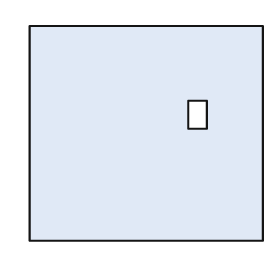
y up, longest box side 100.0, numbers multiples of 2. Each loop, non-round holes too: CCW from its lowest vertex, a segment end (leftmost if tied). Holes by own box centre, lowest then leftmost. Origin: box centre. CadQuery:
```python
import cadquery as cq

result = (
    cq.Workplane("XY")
    .moveTo(-50.0, -46.0)
    .lineTo(50.0, -46.0)
    .lineTo(50.0, 46.0)
    .lineTo(-50.0, 46.0)
    .close()
    .moveTo(18.0, 2.0)
    .lineTo(26.0, 2.0)
    .lineTo(26.0, 14.0)
    .lineTo(18.0, 14.0)
    .close()
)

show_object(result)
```